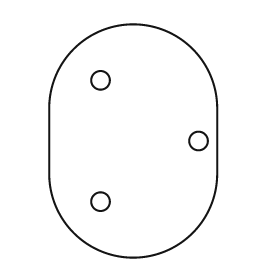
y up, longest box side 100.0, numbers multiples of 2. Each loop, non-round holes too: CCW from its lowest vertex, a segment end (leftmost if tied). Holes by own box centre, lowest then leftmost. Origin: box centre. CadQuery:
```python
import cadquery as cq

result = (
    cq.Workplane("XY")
    .moveTo(-36.0, -14.0)
    .threePointArc((0.0, -50.0), (36.0, -14.0))
    .lineTo(36.0, 14.0)
    .threePointArc((0.0, 50.0), (-36.0, 14.0))
    .close()
    .moveTo(-14.0, -26.0)
    .circle(4.0)
    .moveTo(28.0, 0.0)
    .circle(4.0)
    .moveTo(-14.0, 26.0)
    .circle(4.0)
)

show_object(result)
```